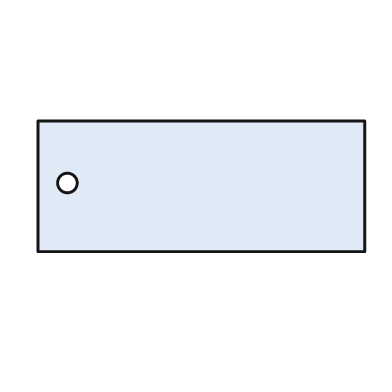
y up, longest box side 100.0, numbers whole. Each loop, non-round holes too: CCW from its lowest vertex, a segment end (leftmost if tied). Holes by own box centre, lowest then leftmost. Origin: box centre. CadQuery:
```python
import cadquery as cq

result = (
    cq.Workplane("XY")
    .moveTo(-50.0, -20.0)
    .lineTo(50.0, -20.0)
    .lineTo(50.0, 20.0)
    .lineTo(-50.0, 20.0)
    .close()
    .moveTo(-41.0, 1.0)
    .circle(3.0)
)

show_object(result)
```